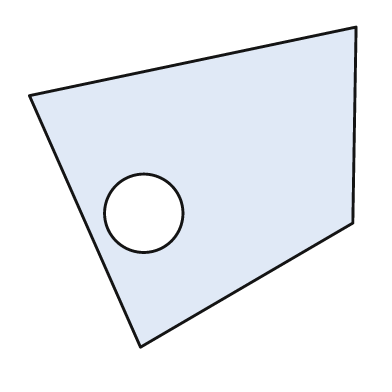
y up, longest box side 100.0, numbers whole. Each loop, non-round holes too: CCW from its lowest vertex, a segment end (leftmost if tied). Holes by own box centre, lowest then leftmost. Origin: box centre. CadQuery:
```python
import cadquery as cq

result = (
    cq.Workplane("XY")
    .moveTo(-16.0, -49.0)
    .lineTo(49.0, -11.0)
    .lineTo(50.0, 49.0)
    .lineTo(-50.0, 28.0)
    .close()
    .moveTo(-15.0, -8.0)
    .circle(12.0)
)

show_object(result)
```